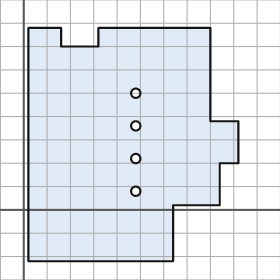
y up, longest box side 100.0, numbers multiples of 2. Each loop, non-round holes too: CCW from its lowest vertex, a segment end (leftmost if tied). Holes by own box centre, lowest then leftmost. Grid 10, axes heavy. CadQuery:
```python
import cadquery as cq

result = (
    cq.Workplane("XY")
    .moveTo(2.0, -22.0)
    .lineTo(64.0, -22.0)
    .lineTo(64.0, 2.0)
    .lineTo(84.0, 2.0)
    .lineTo(84.0, 20.0)
    .lineTo(92.0, 20.0)
    .lineTo(92.0, 38.0)
    .lineTo(80.0, 38.0)
    .lineTo(80.0, 78.0)
    .lineTo(32.0, 78.0)
    .lineTo(32.0, 70.0)
    .lineTo(16.0, 70.0)
    .lineTo(16.0, 78.0)
    .lineTo(2.0, 78.0)
    .close()
    .moveTo(48.0, 8.0)
    .circle(2.0)
    .moveTo(48.0, 22.0)
    .circle(2.0)
    .moveTo(48.0, 36.0)
    .circle(2.0)
    .moveTo(48.0, 50.0)
    .circle(2.0)
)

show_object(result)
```